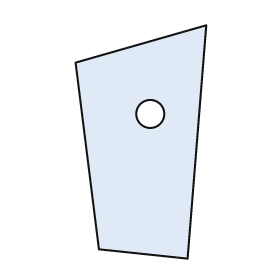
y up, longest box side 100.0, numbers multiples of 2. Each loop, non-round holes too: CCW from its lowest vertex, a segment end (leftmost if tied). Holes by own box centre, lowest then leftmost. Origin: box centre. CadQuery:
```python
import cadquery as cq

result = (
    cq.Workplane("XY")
    .moveTo(20.0, -50.0)
    .lineTo(28.0, 50.0)
    .lineTo(-28.0, 34.0)
    .lineTo(-18.0, -46.0)
    .close()
    .moveTo(4.0, 12.0)
    .circle(6.0)
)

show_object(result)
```